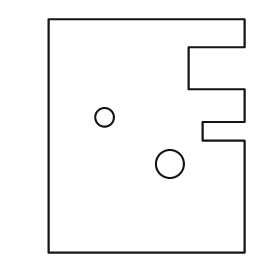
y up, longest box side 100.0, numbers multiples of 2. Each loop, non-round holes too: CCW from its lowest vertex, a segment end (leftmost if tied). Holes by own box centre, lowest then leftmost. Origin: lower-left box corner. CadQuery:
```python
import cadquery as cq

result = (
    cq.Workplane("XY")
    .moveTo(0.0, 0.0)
    .lineTo(84.0, 0.0)
    .lineTo(84.0, 48.0)
    .lineTo(66.0, 48.0)
    .lineTo(66.0, 56.0)
    .lineTo(84.0, 56.0)
    .lineTo(84.0, 70.0)
    .lineTo(60.0, 70.0)
    .lineTo(60.0, 88.0)
    .lineTo(84.0, 88.0)
    .lineTo(84.0, 100.0)
    .lineTo(0.0, 100.0)
    .close()
    .moveTo(52.0, 38.0)
    .circle(6.0)
    .moveTo(24.0, 58.0)
    .circle(4.0)
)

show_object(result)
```